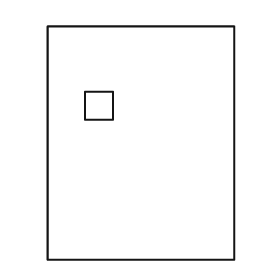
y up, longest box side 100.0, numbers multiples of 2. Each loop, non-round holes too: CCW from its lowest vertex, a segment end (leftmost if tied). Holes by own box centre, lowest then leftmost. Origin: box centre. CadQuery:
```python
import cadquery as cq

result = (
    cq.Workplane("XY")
    .moveTo(-40.0, -50.0)
    .lineTo(40.0, -50.0)
    .lineTo(40.0, 50.0)
    .lineTo(-40.0, 50.0)
    .close()
    .moveTo(-24.0, 10.0)
    .lineTo(-12.0, 10.0)
    .lineTo(-12.0, 22.0)
    .lineTo(-24.0, 22.0)
    .close()
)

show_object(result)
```